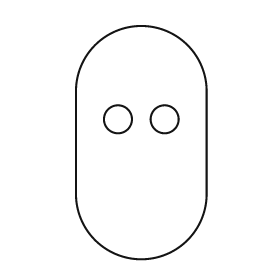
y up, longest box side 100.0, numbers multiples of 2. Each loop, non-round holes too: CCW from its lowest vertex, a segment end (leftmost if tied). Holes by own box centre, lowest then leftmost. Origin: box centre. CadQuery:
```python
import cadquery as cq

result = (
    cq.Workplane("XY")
    .moveTo(-28.0, -22.0)
    .threePointArc((0.0, -50.0), (28.0, -22.0))
    .lineTo(28.0, 22.0)
    .threePointArc((0.0, 50.0), (-28.0, 22.0))
    .close()
    .moveTo(-10.0, 10.0)
    .circle(6.0)
    .moveTo(10.0, 10.0)
    .circle(6.0)
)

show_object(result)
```